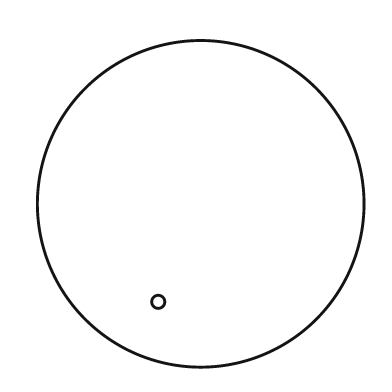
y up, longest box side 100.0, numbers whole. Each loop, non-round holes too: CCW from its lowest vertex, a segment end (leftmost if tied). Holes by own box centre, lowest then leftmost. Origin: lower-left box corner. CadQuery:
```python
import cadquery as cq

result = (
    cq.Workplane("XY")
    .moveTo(50.0, 50.0)
    .circle(50.0)
    .moveTo(37.0, 20.0)
    .circle(2.0)
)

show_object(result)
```